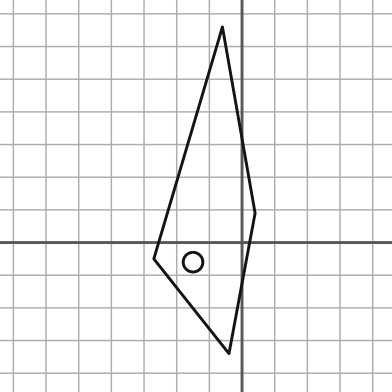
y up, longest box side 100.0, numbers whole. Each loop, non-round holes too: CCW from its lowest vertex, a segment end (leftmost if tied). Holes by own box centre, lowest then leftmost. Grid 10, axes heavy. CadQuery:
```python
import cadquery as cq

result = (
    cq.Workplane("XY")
    .moveTo(-4.0, -34.0)
    .lineTo(4.0, 9.0)
    .lineTo(-6.0, 66.0)
    .lineTo(-27.0, -5.0)
    .close()
    .moveTo(-15.0, -6.0)
    .circle(3.0)
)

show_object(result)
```